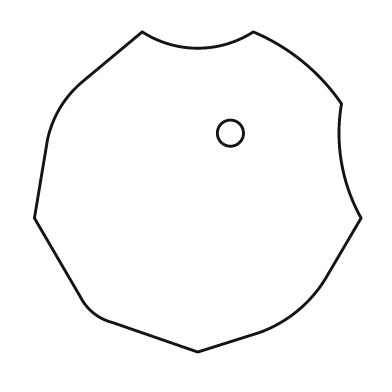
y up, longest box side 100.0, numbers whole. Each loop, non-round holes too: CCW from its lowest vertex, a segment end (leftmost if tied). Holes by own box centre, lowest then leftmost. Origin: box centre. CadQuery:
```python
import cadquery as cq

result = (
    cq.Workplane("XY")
    .moveTo(0.0, -49.0)
    .lineTo(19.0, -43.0)
    .threePointArc((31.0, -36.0), (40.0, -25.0))
    .lineTo(50.0, -8.0)
    .threePointArc((44.0, 9.0), (44.0, 27.0))
    .threePointArc((32.0, 40.0), (17.0, 49.0))
    .threePointArc((0.0, 44.0), (-17.0, 49.0))
    .lineTo(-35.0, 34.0)
    .threePointArc((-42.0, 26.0), (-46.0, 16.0))
    .lineTo(-50.0, -8.0)
    .lineTo(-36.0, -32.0)
    .threePointArc((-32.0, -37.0), (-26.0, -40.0))
    .close()
    .moveTo(10.0, 18.0)
    .circle(4.0)
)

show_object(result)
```